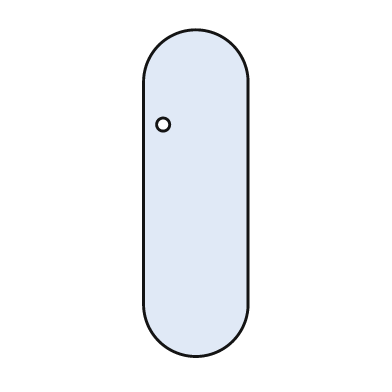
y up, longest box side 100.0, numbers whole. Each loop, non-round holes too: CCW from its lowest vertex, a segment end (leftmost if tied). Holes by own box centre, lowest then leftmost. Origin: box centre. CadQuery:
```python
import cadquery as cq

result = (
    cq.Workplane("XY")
    .moveTo(-16.0, -34.0)
    .threePointArc((0.0, -50.0), (16.0, -34.0))
    .lineTo(16.0, 34.0)
    .threePointArc((0.0, 50.0), (-16.0, 34.0))
    .close()
    .moveTo(-10.0, 21.0)
    .circle(2.0)
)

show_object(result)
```